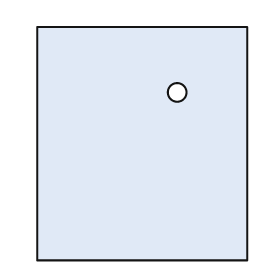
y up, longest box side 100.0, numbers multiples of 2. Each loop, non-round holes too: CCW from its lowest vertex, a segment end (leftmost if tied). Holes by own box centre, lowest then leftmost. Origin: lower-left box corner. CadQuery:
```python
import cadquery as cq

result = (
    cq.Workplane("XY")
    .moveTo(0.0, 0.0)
    .lineTo(90.0, 0.0)
    .lineTo(90.0, 100.0)
    .lineTo(0.0, 100.0)
    .close()
    .moveTo(60.0, 72.0)
    .circle(4.0)
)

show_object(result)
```